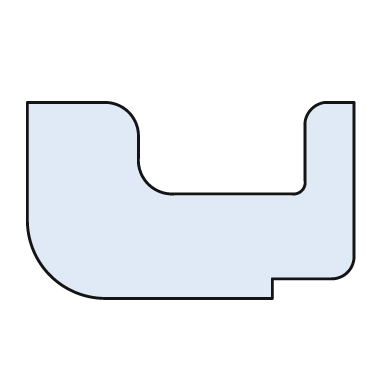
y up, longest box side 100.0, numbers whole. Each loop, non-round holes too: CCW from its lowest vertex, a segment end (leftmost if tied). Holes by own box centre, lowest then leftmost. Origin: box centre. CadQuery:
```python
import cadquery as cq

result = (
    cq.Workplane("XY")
    .moveTo(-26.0, -30.0)
    .lineTo(25.0, -30.0)
    .lineTo(25.0, -24.0)
    .lineTo(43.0, -24.0)
    .threePointArc((48.0, -22.0), (50.0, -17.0))
    .lineTo(50.0, 30.0)
    .lineTo(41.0, 30.0)
    .threePointArc((37.0, 28.0), (35.0, 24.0))
    .lineTo(35.0, 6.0)
    .threePointArc((34.0, 3.0), (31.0, 2.0))
    .lineTo(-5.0, 2.0)
    .threePointArc((-13.0, 5.0), (-16.0, 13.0))
    .lineTo(-16.0, 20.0)
    .threePointArc((-19.0, 27.0), (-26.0, 30.0))
    .lineTo(-50.0, 30.0)
    .lineTo(-50.0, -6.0)
    .threePointArc((-43.0, -23.0), (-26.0, -30.0))
    .close()
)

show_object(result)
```